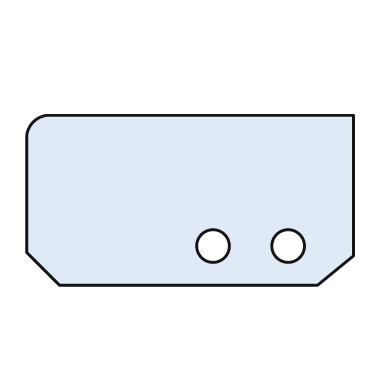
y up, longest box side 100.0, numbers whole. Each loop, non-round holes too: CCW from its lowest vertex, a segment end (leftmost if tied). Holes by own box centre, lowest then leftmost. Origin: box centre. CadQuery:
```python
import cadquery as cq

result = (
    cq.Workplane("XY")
    .moveTo(-40.0, -26.0)
    .lineTo(39.0, -26.0)
    .lineTo(50.0, -17.0)
    .lineTo(50.0, 26.0)
    .lineTo(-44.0, 26.0)
    .threePointArc((-48.0, 24.0), (-50.0, 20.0))
    .lineTo(-50.0, -16.0)
    .close()
    .moveTo(7.0, -14.0)
    .circle(5.0)
    .moveTo(30.0, -14.0)
    .circle(5.0)
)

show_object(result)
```